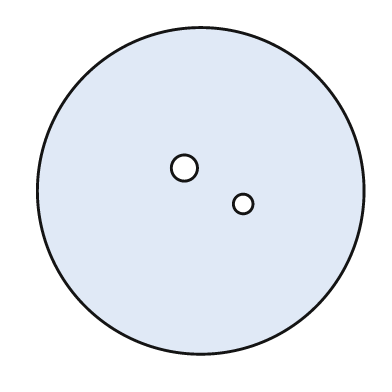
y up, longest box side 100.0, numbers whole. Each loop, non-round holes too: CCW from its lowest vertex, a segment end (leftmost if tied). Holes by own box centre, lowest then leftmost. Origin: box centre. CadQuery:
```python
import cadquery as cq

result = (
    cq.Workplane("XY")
    .moveTo(0.0, 0.0)
    .circle(50.0)
    .moveTo(13.0, -4.0)
    .circle(3.0)
    .moveTo(-5.0, 7.0)
    .circle(4.0)
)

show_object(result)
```